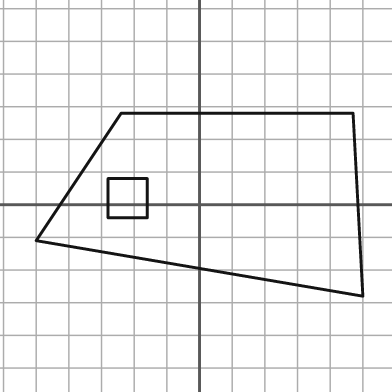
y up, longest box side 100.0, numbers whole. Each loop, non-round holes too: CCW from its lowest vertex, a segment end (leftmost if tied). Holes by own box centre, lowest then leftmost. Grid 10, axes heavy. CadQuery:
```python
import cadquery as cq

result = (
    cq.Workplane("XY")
    .moveTo(50.0, -28.0)
    .lineTo(47.0, 28.0)
    .lineTo(-24.0, 28.0)
    .lineTo(-50.0, -11.0)
    .close()
    .moveTo(-28.0, -4.0)
    .lineTo(-16.0, -4.0)
    .lineTo(-16.0, 8.0)
    .lineTo(-28.0, 8.0)
    .close()
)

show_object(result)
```